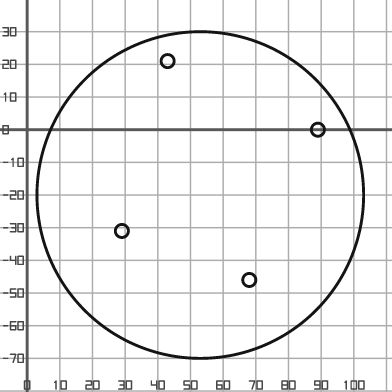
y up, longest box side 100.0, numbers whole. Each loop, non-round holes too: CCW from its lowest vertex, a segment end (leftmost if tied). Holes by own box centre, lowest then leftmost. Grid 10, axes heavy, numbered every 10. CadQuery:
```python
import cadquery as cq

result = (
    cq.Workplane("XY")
    .moveTo(53.0, -20.0)
    .circle(50.0)
    .moveTo(68.0, -46.0)
    .circle(2.0)
    .moveTo(29.0, -31.0)
    .circle(2.0)
    .moveTo(89.0, 0.0)
    .circle(2.0)
    .moveTo(43.0, 21.0)
    .circle(2.0)
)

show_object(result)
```